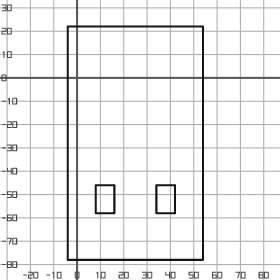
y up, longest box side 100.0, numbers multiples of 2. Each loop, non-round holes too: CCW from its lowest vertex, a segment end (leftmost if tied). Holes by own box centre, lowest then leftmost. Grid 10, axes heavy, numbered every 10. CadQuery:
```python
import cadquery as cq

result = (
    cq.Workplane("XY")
    .moveTo(-4.0, -78.0)
    .lineTo(54.0, -78.0)
    .lineTo(54.0, 22.0)
    .lineTo(-4.0, 22.0)
    .close()
    .moveTo(8.0, -58.0)
    .lineTo(16.0, -58.0)
    .lineTo(16.0, -46.0)
    .lineTo(8.0, -46.0)
    .close()
    .moveTo(34.0, -58.0)
    .lineTo(42.0, -58.0)
    .lineTo(42.0, -46.0)
    .lineTo(34.0, -46.0)
    .close()
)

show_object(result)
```